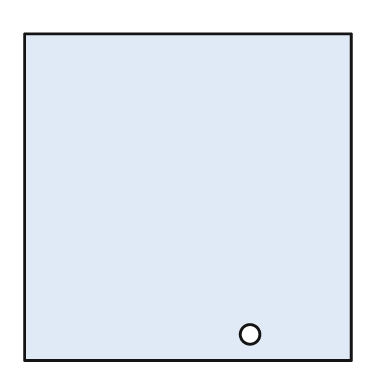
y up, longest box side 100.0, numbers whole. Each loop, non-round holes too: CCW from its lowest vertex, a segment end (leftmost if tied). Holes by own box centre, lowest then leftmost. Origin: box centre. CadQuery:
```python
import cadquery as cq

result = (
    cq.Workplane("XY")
    .moveTo(-50.0, -50.0)
    .lineTo(50.0, -50.0)
    .lineTo(50.0, 50.0)
    .lineTo(-50.0, 50.0)
    .close()
    .moveTo(19.0, -42.0)
    .circle(3.0)
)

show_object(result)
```